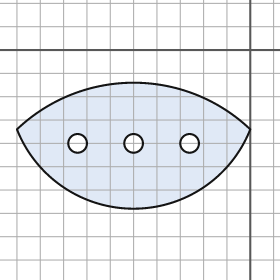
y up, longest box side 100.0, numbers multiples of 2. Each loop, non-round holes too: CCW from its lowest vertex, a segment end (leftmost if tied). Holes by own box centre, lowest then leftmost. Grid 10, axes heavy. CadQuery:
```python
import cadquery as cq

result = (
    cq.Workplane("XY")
    .moveTo(-100.0, -34.0)
    .threePointArc((-50.0, -68.0), (0.0, -34.0))
    .threePointArc((-50.0, -14.0), (-100.0, -34.0))
    .close()
    .moveTo(-74.0, -40.0)
    .circle(4.0)
    .moveTo(-50.0, -40.0)
    .circle(4.0)
    .moveTo(-26.0, -40.0)
    .circle(4.0)
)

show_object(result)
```